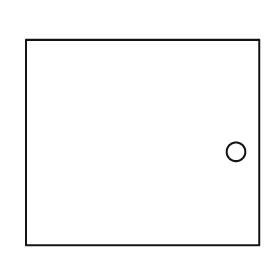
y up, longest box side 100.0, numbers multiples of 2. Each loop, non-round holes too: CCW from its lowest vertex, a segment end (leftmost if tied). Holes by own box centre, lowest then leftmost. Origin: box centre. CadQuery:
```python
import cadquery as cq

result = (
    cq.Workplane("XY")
    .moveTo(-50.0, -44.0)
    .lineTo(50.0, -44.0)
    .lineTo(50.0, 44.0)
    .lineTo(-50.0, 44.0)
    .close()
    .moveTo(40.0, -4.0)
    .circle(4.0)
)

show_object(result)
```